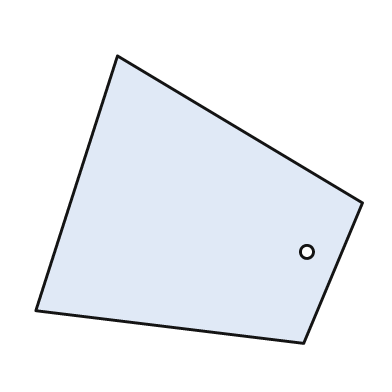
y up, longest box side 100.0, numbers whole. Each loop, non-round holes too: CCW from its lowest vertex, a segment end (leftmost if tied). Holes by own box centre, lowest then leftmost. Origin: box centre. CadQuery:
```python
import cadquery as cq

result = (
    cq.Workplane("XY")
    .moveTo(32.0, -44.0)
    .lineTo(50.0, -1.0)
    .lineTo(-25.0, 44.0)
    .lineTo(-50.0, -34.0)
    .close()
    .moveTo(33.0, -16.0)
    .circle(2.0)
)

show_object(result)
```